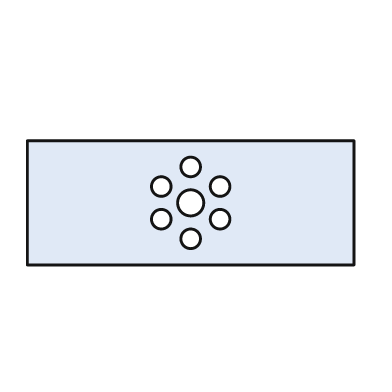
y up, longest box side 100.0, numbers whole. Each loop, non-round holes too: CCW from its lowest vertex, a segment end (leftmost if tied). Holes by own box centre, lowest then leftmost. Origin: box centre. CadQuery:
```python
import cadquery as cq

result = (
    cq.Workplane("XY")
    .moveTo(-50.0, -19.0)
    .lineTo(50.0, -19.0)
    .lineTo(50.0, 19.0)
    .lineTo(-50.0, 19.0)
    .close()
    .moveTo(0.0, -11.0)
    .circle(3.0)
    .moveTo(-9.0, -5.0)
    .circle(3.0)
    .moveTo(9.0, -5.0)
    .circle(3.0)
    .moveTo(0.0, 0.0)
    .circle(4.0)
    .moveTo(-9.0, 5.0)
    .circle(3.0)
    .moveTo(9.0, 5.0)
    .circle(3.0)
    .moveTo(0.0, 11.0)
    .circle(3.0)
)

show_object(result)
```